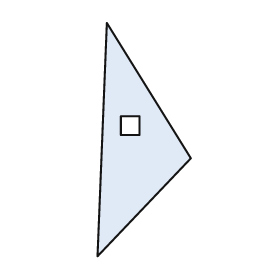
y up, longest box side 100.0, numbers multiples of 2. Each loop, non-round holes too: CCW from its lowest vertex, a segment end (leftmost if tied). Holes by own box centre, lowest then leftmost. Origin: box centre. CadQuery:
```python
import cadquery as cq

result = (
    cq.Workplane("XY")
    .moveTo(-20.0, -50.0)
    .lineTo(20.0, -8.0)
    .lineTo(-16.0, 50.0)
    .close()
    .moveTo(-10.0, 2.0)
    .lineTo(-2.0, 2.0)
    .lineTo(-2.0, 10.0)
    .lineTo(-10.0, 10.0)
    .close()
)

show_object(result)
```